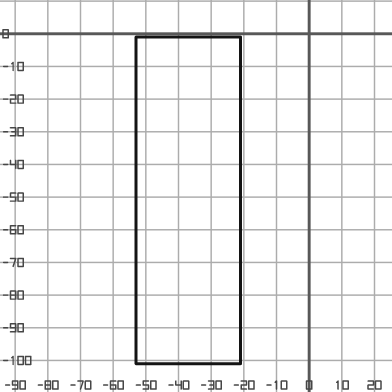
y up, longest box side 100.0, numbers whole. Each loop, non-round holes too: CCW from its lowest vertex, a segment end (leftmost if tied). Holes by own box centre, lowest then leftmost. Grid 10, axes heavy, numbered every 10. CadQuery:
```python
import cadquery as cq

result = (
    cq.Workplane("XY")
    .moveTo(-53.0, -101.0)
    .lineTo(-21.0, -101.0)
    .lineTo(-21.0, -1.0)
    .lineTo(-53.0, -1.0)
    .close()
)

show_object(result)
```